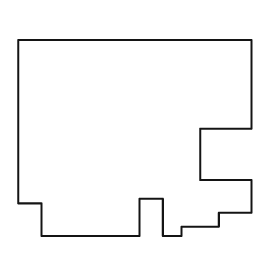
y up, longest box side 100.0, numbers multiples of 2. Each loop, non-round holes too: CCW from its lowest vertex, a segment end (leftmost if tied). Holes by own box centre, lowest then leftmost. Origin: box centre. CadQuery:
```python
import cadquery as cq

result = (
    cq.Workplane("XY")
    .moveTo(-40.0, -42.0)
    .lineTo(2.0, -42.0)
    .lineTo(2.0, -26.0)
    .lineTo(12.0, -26.0)
    .lineTo(12.0, -42.0)
    .lineTo(20.0, -42.0)
    .lineTo(20.0, -38.0)
    .lineTo(36.0, -38.0)
    .lineTo(36.0, -32.0)
    .lineTo(50.0, -32.0)
    .lineTo(50.0, -18.0)
    .lineTo(28.0, -18.0)
    .lineTo(28.0, 4.0)
    .lineTo(50.0, 4.0)
    .lineTo(50.0, 42.0)
    .lineTo(-50.0, 42.0)
    .lineTo(-50.0, -28.0)
    .lineTo(-40.0, -28.0)
    .close()
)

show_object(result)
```